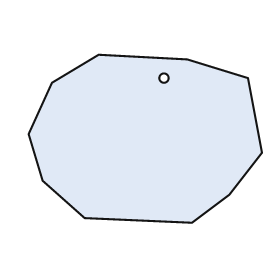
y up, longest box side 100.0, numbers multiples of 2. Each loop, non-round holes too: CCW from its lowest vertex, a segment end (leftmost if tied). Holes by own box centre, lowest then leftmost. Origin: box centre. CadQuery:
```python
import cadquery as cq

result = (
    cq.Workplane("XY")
    .moveTo(20.0, -36.0)
    .lineTo(36.0, -24.0)
    .lineTo(50.0, -6.0)
    .lineTo(44.0, 26.0)
    .lineTo(18.0, 34.0)
    .lineTo(-20.0, 36.0)
    .lineTo(-40.0, 24.0)
    .lineTo(-50.0, 2.0)
    .lineTo(-44.0, -18.0)
    .lineTo(-26.0, -34.0)
    .close()
    .moveTo(8.0, 26.0)
    .circle(2.0)
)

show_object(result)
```